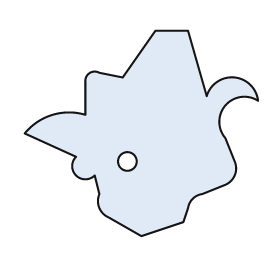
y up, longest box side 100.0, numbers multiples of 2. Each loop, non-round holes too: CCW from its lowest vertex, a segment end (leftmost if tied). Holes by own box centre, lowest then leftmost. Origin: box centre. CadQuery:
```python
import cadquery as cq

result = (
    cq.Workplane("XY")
    .moveTo(0.0, -44.0)
    .lineTo(18.0, -38.0)
    .lineTo(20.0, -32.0)
    .threePointArc((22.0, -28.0), (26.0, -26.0))
    .lineTo(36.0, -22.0)
    .threePointArc((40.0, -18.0), (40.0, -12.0))
    .lineTo(36.0, -2.0)
    .threePointArc((36.0, 12.0), (50.0, 14.0))
    .threePointArc((40.0, 24.0), (28.0, 16.0))
    .lineTo(20.0, 44.0)
    .lineTo(6.0, 44.0)
    .lineTo(-8.0, 24.0)
    .lineTo(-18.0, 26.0)
    .threePointArc((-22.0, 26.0), (-24.0, 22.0))
    .lineTo(-24.0, 8.0)
    .threePointArc((-38.0, 8.0), (-50.0, 0.0))
    .lineTo(-28.0, -10.0)
    .threePointArc((-28.0, -18.0), (-20.0, -18.0))
    .lineTo(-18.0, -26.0)
    .threePointArc((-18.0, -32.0), (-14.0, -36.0))
    .close()
    .moveTo(-6.0, -12.0)
    .circle(4.0)
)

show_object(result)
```